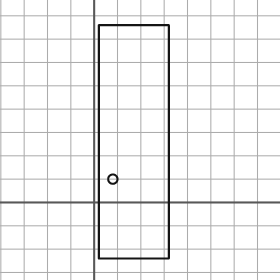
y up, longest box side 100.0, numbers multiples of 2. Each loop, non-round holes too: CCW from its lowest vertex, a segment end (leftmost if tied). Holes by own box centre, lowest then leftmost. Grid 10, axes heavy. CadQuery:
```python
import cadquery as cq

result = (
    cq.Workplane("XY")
    .moveTo(2.0, -24.0)
    .lineTo(32.0, -24.0)
    .lineTo(32.0, 76.0)
    .lineTo(2.0, 76.0)
    .close()
    .moveTo(8.0, 10.0)
    .circle(2.0)
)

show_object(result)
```